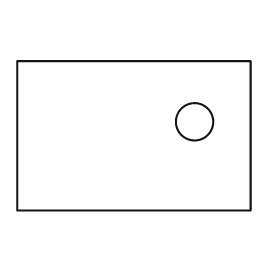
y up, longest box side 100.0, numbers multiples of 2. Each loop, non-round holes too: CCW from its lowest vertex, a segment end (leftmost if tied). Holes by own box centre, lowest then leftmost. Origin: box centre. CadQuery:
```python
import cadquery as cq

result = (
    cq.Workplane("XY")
    .moveTo(-50.0, -32.0)
    .lineTo(50.0, -32.0)
    .lineTo(50.0, 32.0)
    .lineTo(-50.0, 32.0)
    .close()
    .moveTo(26.0, 6.0)
    .circle(8.0)
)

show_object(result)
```